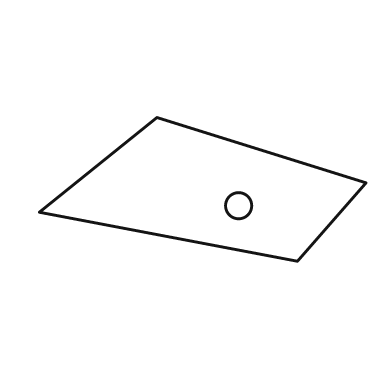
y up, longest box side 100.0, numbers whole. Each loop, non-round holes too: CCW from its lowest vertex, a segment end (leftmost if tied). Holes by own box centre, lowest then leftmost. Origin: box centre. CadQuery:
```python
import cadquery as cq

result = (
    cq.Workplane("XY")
    .moveTo(29.0, -22.0)
    .lineTo(50.0, 2.0)
    .lineTo(-14.0, 22.0)
    .lineTo(-50.0, -7.0)
    .close()
    .moveTo(11.0, -5.0)
    .circle(4.0)
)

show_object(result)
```